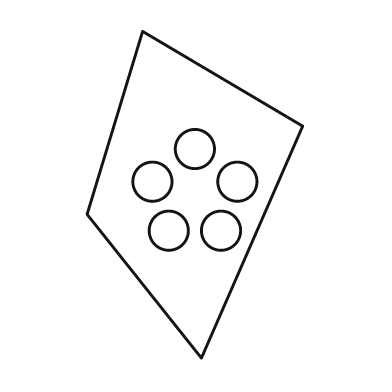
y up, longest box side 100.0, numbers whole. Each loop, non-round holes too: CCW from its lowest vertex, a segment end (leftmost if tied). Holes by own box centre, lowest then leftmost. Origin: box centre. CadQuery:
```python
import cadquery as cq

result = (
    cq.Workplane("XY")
    .moveTo(2.0, -50.0)
    .lineTo(33.0, 21.0)
    .lineTo(-16.0, 50.0)
    .lineTo(-33.0, -6.0)
    .close()
    .moveTo(-8.0, -11.0)
    .circle(6.0)
    .moveTo(8.0, -11.0)
    .circle(6.0)
    .moveTo(-13.0, 4.0)
    .circle(6.0)
    .moveTo(13.0, 4.0)
    .circle(6.0)
    .moveTo(0.0, 14.0)
    .circle(6.0)
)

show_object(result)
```